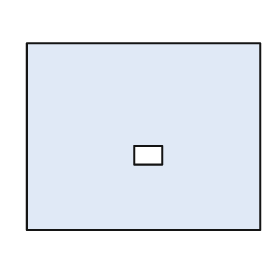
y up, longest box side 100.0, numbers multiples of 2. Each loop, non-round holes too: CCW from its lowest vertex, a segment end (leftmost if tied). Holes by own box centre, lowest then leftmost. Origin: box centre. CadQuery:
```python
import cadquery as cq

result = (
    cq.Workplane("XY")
    .moveTo(-50.0, -40.0)
    .lineTo(50.0, -40.0)
    .lineTo(50.0, 40.0)
    .lineTo(-50.0, 40.0)
    .close()
    .moveTo(-4.0, -12.0)
    .lineTo(8.0, -12.0)
    .lineTo(8.0, -4.0)
    .lineTo(-4.0, -4.0)
    .close()
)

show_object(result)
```